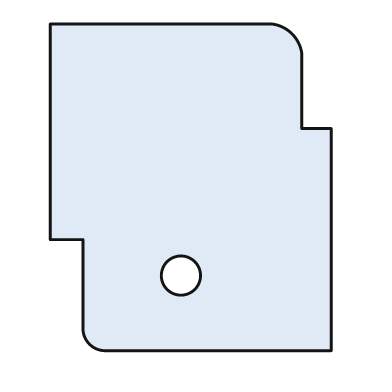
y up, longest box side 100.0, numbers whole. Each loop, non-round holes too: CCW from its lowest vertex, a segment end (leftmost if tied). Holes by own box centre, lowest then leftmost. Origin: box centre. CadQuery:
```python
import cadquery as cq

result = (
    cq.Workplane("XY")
    .moveTo(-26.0, -50.0)
    .lineTo(43.0, -50.0)
    .lineTo(43.0, 18.0)
    .lineTo(34.0, 18.0)
    .lineTo(34.0, 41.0)
    .threePointArc((31.0, 47.0), (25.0, 50.0))
    .lineTo(-43.0, 50.0)
    .lineTo(-43.0, -16.0)
    .lineTo(-33.0, -16.0)
    .lineTo(-33.0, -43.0)
    .threePointArc((-31.0, -48.0), (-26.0, -50.0))
    .close()
    .moveTo(-3.0, -27.0)
    .circle(6.0)
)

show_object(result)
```